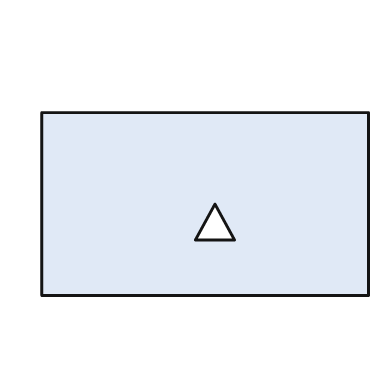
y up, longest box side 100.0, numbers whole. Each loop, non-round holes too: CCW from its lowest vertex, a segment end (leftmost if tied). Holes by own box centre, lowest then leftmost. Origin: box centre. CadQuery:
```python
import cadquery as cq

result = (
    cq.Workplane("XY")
    .moveTo(-50.0, -28.0)
    .lineTo(50.0, -28.0)
    .lineTo(50.0, 28.0)
    .lineTo(-50.0, 28.0)
    .close()
    .moveTo(-3.0, -11.0)
    .lineTo(9.0, -11.0)
    .lineTo(3.0, 0.0)
    .close()
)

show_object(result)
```